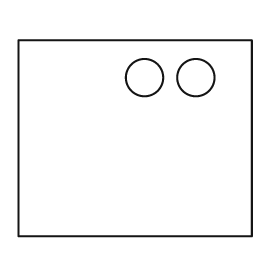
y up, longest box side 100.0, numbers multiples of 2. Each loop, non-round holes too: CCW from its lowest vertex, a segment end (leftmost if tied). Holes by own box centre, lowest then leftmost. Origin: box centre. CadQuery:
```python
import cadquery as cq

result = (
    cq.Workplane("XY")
    .moveTo(-50.0, -42.0)
    .lineTo(50.0, -42.0)
    .lineTo(50.0, 42.0)
    .lineTo(-50.0, 42.0)
    .close()
    .moveTo(4.0, 26.0)
    .circle(8.0)
    .moveTo(26.0, 26.0)
    .circle(8.0)
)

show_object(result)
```